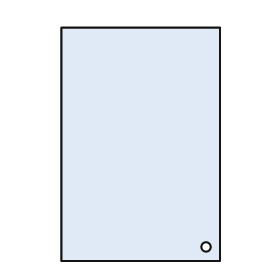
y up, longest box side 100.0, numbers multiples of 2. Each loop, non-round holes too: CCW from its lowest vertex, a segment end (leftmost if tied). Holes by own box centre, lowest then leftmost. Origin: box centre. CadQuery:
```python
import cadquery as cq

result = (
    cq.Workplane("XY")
    .moveTo(-34.0, -50.0)
    .lineTo(34.0, -50.0)
    .lineTo(34.0, 50.0)
    .lineTo(-34.0, 50.0)
    .close()
    .moveTo(28.0, -44.0)
    .circle(2.0)
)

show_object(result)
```